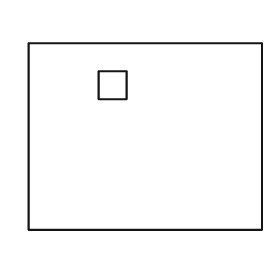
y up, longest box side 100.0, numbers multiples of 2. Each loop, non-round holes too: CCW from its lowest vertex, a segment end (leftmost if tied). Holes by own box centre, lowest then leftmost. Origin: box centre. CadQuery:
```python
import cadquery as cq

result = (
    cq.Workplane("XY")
    .moveTo(-50.0, -40.0)
    .lineTo(50.0, -40.0)
    .lineTo(50.0, 40.0)
    .lineTo(-50.0, 40.0)
    .close()
    .moveTo(-20.0, 16.0)
    .lineTo(-8.0, 16.0)
    .lineTo(-8.0, 28.0)
    .lineTo(-20.0, 28.0)
    .close()
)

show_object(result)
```